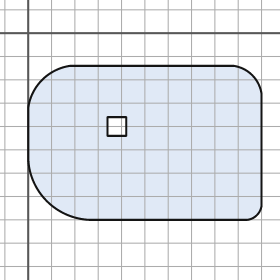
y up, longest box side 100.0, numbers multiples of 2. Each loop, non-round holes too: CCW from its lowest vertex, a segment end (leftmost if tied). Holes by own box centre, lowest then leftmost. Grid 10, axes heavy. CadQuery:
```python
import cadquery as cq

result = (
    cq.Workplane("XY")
    .moveTo(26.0, -80.0)
    .lineTo(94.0, -80.0)
    .threePointArc((98.0, -78.0), (100.0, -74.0))
    .lineTo(100.0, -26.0)
    .threePointArc((96.0, -18.0), (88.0, -14.0))
    .lineTo(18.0, -14.0)
    .threePointArc((6.0, -20.0), (0.0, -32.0))
    .lineTo(0.0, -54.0)
    .threePointArc((8.0, -72.0), (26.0, -80.0))
    .close()
    .moveTo(34.0, -44.0)
    .lineTo(42.0, -44.0)
    .lineTo(42.0, -36.0)
    .lineTo(34.0, -36.0)
    .close()
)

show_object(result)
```